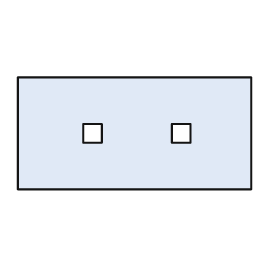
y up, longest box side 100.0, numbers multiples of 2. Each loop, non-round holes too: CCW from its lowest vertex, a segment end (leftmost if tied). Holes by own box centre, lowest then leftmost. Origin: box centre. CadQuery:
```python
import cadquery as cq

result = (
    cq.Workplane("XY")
    .moveTo(-50.0, -24.0)
    .lineTo(50.0, -24.0)
    .lineTo(50.0, 24.0)
    .lineTo(-50.0, 24.0)
    .close()
    .moveTo(-22.0, -4.0)
    .lineTo(-14.0, -4.0)
    .lineTo(-14.0, 4.0)
    .lineTo(-22.0, 4.0)
    .close()
    .moveTo(16.0, -4.0)
    .lineTo(24.0, -4.0)
    .lineTo(24.0, 4.0)
    .lineTo(16.0, 4.0)
    .close()
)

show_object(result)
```